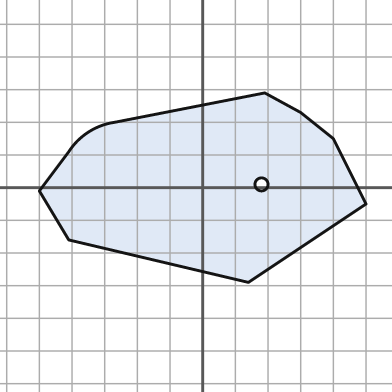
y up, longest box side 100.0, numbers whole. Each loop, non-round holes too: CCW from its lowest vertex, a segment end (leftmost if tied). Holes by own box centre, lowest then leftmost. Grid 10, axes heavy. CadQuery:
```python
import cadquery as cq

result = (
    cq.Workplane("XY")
    .moveTo(14.0, -29.0)
    .lineTo(50.0, -5.0)
    .lineTo(40.0, 15.0)
    .lineTo(30.0, 23.0)
    .lineTo(19.0, 29.0)
    .lineTo(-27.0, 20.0)
    .threePointArc((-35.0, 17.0), (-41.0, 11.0))
    .lineTo(-50.0, -1.0)
    .lineTo(-41.0, -16.0)
    .close()
    .moveTo(18.0, 1.0)
    .circle(2.0)
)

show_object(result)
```